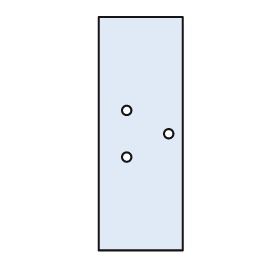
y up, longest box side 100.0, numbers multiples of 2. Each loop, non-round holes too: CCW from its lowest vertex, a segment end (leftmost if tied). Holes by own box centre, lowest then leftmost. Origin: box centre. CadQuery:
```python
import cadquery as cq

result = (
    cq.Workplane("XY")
    .moveTo(-18.0, -50.0)
    .lineTo(18.0, -50.0)
    .lineTo(18.0, 50.0)
    .lineTo(-18.0, 50.0)
    .close()
    .moveTo(-6.0, -10.0)
    .circle(2.0)
    .moveTo(12.0, 0.0)
    .circle(2.0)
    .moveTo(-6.0, 10.0)
    .circle(2.0)
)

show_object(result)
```